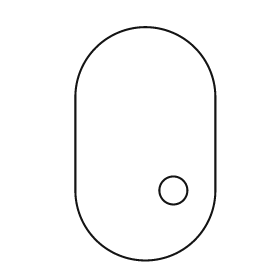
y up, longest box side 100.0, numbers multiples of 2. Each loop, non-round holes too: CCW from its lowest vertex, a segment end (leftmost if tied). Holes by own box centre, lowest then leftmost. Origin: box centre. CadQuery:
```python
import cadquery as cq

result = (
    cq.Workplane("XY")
    .moveTo(-30.0, -20.0)
    .threePointArc((0.0, -50.0), (30.0, -20.0))
    .lineTo(30.0, 20.0)
    .threePointArc((0.0, 50.0), (-30.0, 20.0))
    .close()
    .moveTo(12.0, -20.0)
    .circle(6.0)
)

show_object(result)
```